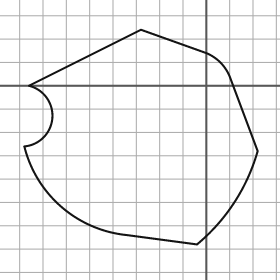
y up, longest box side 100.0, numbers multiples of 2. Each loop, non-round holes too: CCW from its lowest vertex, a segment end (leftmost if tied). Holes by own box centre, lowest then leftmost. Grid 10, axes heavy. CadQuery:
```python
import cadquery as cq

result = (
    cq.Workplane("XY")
    .moveTo(-4.0, -68.0)
    .threePointArc((12.0, -50.0), (22.0, -28.0))
    .lineTo(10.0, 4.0)
    .threePointArc((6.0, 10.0), (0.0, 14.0))
    .lineTo(-28.0, 24.0)
    .lineTo(-76.0, 0.0)
    .threePointArc((-66.0, -14.0), (-78.0, -26.0))
    .threePointArc((-62.0, -52.0), (-34.0, -64.0))
    .close()
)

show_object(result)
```